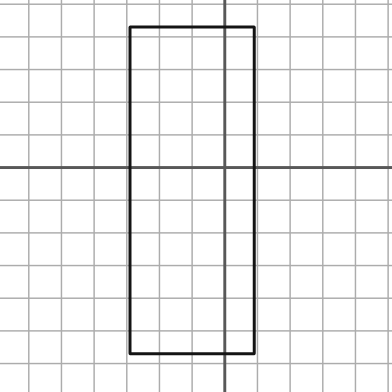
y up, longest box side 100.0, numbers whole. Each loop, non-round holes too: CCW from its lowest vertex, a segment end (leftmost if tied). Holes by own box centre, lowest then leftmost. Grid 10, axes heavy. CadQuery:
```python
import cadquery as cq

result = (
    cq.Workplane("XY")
    .moveTo(-29.0, -57.0)
    .lineTo(9.0, -57.0)
    .lineTo(9.0, 43.0)
    .lineTo(-29.0, 43.0)
    .close()
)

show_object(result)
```